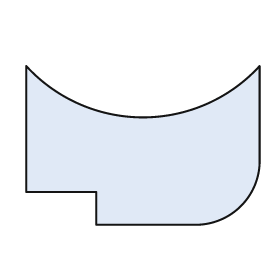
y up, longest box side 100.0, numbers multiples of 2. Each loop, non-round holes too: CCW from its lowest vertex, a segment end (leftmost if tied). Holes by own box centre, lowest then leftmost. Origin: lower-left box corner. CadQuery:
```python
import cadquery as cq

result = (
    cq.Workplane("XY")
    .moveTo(30.0, 0.0)
    .lineTo(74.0, 0.0)
    .threePointArc((92.0, 8.0), (100.0, 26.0))
    .lineTo(100.0, 68.0)
    .threePointArc((50.0, 46.0), (0.0, 68.0))
    .lineTo(0.0, 14.0)
    .lineTo(30.0, 14.0)
    .close()
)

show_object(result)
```